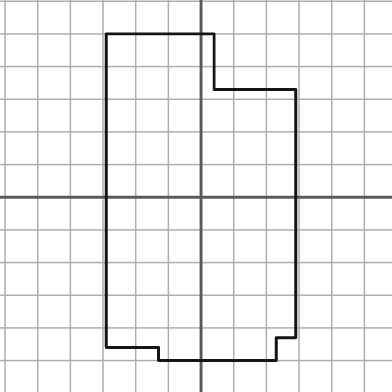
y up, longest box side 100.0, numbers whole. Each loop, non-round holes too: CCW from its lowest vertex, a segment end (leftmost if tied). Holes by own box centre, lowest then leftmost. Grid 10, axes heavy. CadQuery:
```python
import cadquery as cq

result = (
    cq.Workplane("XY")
    .moveTo(-13.0, -50.0)
    .lineTo(23.0, -50.0)
    .lineTo(23.0, -43.0)
    .lineTo(29.0, -43.0)
    .lineTo(29.0, 33.0)
    .lineTo(4.0, 33.0)
    .lineTo(4.0, 50.0)
    .lineTo(-29.0, 50.0)
    .lineTo(-29.0, -46.0)
    .lineTo(-13.0, -46.0)
    .close()
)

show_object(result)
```